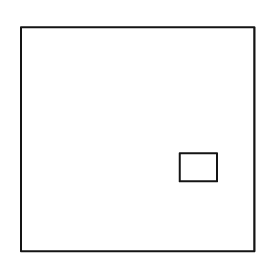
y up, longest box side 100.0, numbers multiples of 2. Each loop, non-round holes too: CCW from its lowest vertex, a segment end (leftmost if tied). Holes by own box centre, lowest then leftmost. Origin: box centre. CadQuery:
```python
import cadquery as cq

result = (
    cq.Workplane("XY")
    .moveTo(-50.0, -48.0)
    .lineTo(50.0, -48.0)
    .lineTo(50.0, 48.0)
    .lineTo(-50.0, 48.0)
    .close()
    .moveTo(18.0, -18.0)
    .lineTo(34.0, -18.0)
    .lineTo(34.0, -6.0)
    .lineTo(18.0, -6.0)
    .close()
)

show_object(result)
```